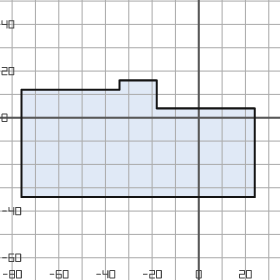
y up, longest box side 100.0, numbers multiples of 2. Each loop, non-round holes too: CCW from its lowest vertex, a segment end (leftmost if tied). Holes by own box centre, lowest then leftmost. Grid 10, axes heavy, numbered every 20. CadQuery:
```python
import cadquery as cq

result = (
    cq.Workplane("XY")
    .moveTo(-76.0, -34.0)
    .lineTo(24.0, -34.0)
    .lineTo(24.0, 4.0)
    .lineTo(-18.0, 4.0)
    .lineTo(-18.0, 16.0)
    .lineTo(-34.0, 16.0)
    .lineTo(-34.0, 12.0)
    .lineTo(-76.0, 12.0)
    .close()
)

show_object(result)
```